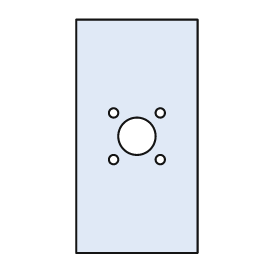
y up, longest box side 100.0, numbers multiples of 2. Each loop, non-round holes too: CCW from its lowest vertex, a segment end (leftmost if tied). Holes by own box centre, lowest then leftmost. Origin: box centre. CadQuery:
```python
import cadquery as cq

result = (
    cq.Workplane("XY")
    .moveTo(-26.0, -50.0)
    .lineTo(26.0, -50.0)
    .lineTo(26.0, 50.0)
    .lineTo(-26.0, 50.0)
    .close()
    .moveTo(-10.0, -10.0)
    .circle(2.0)
    .moveTo(10.0, -10.0)
    .circle(2.0)
    .moveTo(0.0, 0.0)
    .circle(8.0)
    .moveTo(-10.0, 10.0)
    .circle(2.0)
    .moveTo(10.0, 10.0)
    .circle(2.0)
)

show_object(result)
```